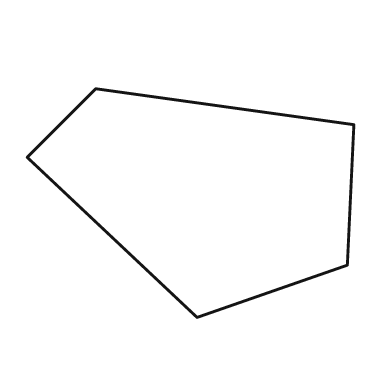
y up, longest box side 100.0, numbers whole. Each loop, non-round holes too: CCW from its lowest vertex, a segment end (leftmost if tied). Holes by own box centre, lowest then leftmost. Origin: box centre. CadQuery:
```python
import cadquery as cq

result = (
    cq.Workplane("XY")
    .moveTo(2.0, -35.0)
    .lineTo(48.0, -19.0)
    .lineTo(50.0, 24.0)
    .lineTo(-29.0, 35.0)
    .lineTo(-50.0, 14.0)
    .close()
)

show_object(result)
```